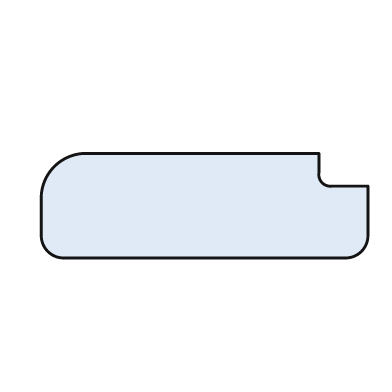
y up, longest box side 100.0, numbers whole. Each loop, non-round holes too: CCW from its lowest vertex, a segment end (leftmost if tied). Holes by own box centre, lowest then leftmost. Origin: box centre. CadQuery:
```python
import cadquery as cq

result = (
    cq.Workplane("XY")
    .moveTo(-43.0, -16.0)
    .lineTo(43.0, -16.0)
    .threePointArc((48.0, -14.0), (50.0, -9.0))
    .lineTo(50.0, 6.0)
    .lineTo(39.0, 6.0)
    .threePointArc((36.0, 7.0), (35.0, 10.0))
    .lineTo(35.0, 16.0)
    .lineTo(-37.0, 16.0)
    .threePointArc((-46.0, 12.0), (-50.0, 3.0))
    .lineTo(-50.0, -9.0)
    .threePointArc((-48.0, -14.0), (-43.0, -16.0))
    .close()
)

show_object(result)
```